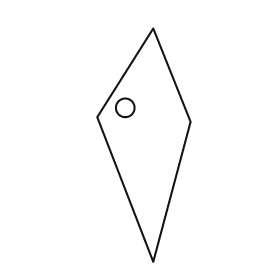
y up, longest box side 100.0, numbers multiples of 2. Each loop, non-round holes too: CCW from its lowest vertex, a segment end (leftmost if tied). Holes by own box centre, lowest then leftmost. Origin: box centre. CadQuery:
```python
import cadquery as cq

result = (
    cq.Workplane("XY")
    .moveTo(4.0, -50.0)
    .lineTo(20.0, 10.0)
    .lineTo(4.0, 50.0)
    .lineTo(-20.0, 12.0)
    .close()
    .moveTo(-8.0, 16.0)
    .circle(4.0)
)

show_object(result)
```